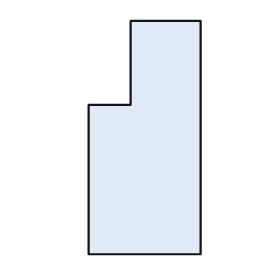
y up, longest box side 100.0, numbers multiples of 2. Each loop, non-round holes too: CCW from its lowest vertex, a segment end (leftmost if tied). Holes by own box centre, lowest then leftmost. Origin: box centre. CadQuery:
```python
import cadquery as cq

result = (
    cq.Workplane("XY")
    .moveTo(-24.0, -50.0)
    .lineTo(24.0, -50.0)
    .lineTo(24.0, 50.0)
    .lineTo(-6.0, 50.0)
    .lineTo(-6.0, 14.0)
    .lineTo(-24.0, 14.0)
    .close()
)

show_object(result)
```